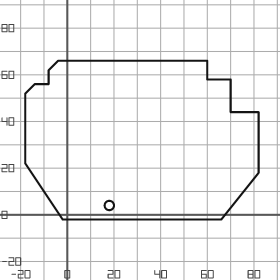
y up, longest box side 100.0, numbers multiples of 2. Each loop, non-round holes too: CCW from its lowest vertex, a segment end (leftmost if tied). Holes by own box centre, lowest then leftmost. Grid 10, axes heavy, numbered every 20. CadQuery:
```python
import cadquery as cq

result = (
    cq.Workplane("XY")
    .moveTo(-2.0, -2.0)
    .lineTo(66.0, -2.0)
    .lineTo(82.0, 18.0)
    .lineTo(82.0, 44.0)
    .lineTo(70.0, 44.0)
    .lineTo(70.0, 58.0)
    .lineTo(60.0, 58.0)
    .lineTo(60.0, 66.0)
    .lineTo(-4.0, 66.0)
    .lineTo(-8.0, 62.0)
    .lineTo(-8.0, 56.0)
    .lineTo(-14.0, 56.0)
    .lineTo(-18.0, 52.0)
    .lineTo(-18.0, 22.0)
    .close()
    .moveTo(18.0, 4.0)
    .circle(2.0)
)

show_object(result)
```